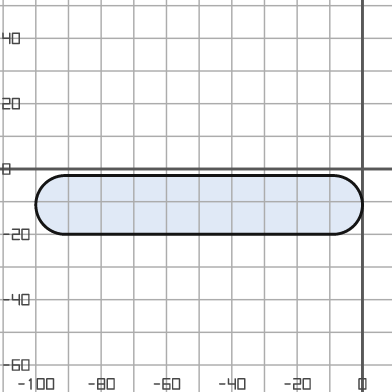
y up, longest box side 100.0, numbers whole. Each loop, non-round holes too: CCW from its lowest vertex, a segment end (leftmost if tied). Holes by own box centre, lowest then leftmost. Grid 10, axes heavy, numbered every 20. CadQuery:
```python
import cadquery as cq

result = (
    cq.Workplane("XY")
    .moveTo(-91.0, -20.0)
    .lineTo(-9.0, -20.0)
    .threePointArc((0.0, -11.0), (-9.0, -2.0))
    .lineTo(-91.0, -2.0)
    .threePointArc((-100.0, -11.0), (-91.0, -20.0))
    .close()
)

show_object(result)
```